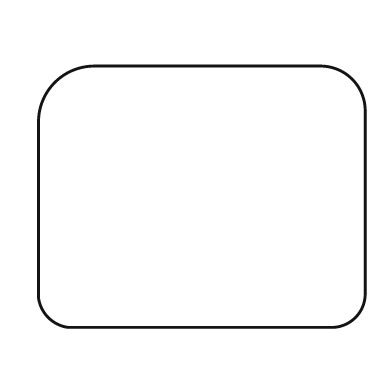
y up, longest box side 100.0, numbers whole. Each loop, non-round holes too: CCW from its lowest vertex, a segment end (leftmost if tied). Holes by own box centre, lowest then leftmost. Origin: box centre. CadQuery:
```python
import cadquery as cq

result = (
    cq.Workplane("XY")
    .moveTo(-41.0, -40.0)
    .lineTo(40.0, -40.0)
    .threePointArc((47.0, -37.0), (50.0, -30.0))
    .lineTo(50.0, 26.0)
    .threePointArc((46.0, 36.0), (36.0, 40.0))
    .lineTo(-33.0, 40.0)
    .threePointArc((-45.0, 35.0), (-50.0, 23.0))
    .lineTo(-50.0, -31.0)
    .threePointArc((-47.0, -37.0), (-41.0, -40.0))
    .close()
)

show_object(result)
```